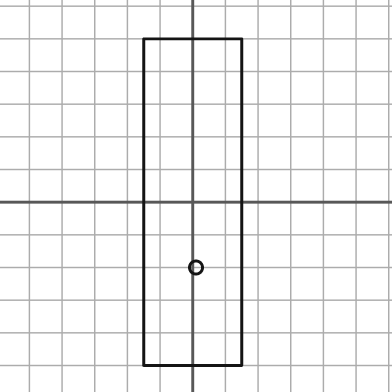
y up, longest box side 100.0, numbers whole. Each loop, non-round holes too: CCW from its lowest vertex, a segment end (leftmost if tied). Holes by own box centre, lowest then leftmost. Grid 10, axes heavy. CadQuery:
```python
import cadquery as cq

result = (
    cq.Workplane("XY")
    .moveTo(-15.0, -50.0)
    .lineTo(15.0, -50.0)
    .lineTo(15.0, 50.0)
    .lineTo(-15.0, 50.0)
    .close()
    .moveTo(1.0, -20.0)
    .circle(2.0)
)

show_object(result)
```